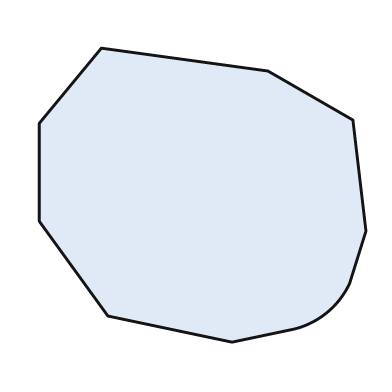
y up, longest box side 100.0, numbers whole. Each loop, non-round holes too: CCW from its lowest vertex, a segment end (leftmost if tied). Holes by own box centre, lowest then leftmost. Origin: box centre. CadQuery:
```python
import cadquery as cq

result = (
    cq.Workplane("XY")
    .moveTo(9.0, -45.0)
    .lineTo(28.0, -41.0)
    .threePointArc((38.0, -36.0), (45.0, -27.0))
    .lineTo(50.0, -11.0)
    .lineTo(46.0, 23.0)
    .lineTo(20.0, 38.0)
    .lineTo(-31.0, 45.0)
    .lineTo(-50.0, 22.0)
    .lineTo(-50.0, -8.0)
    .lineTo(-29.0, -37.0)
    .close()
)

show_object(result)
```